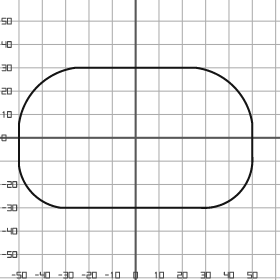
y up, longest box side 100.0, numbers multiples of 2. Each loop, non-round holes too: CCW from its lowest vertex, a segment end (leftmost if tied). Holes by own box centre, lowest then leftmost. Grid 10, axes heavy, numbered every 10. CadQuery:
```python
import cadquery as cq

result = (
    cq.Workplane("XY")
    .moveTo(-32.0, -30.0)
    .lineTo(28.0, -30.0)
    .threePointArc((44.0, -24.0), (50.0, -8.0))
    .lineTo(50.0, 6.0)
    .threePointArc((42.0, 22.0), (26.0, 30.0))
    .lineTo(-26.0, 30.0)
    .threePointArc((-42.0, 22.0), (-50.0, 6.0))
    .lineTo(-50.0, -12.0)
    .threePointArc((-44.0, -24.0), (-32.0, -30.0))
    .close()
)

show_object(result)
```